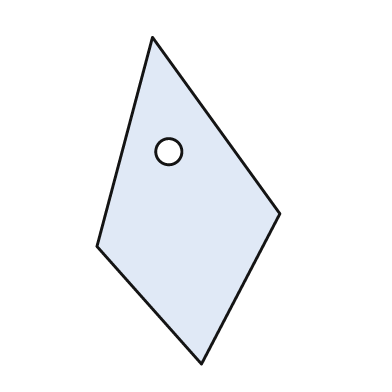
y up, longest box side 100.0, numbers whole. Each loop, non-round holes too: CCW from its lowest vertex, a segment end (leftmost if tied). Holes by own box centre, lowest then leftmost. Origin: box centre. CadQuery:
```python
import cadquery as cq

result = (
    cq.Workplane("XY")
    .moveTo(4.0, -50.0)
    .lineTo(28.0, -4.0)
    .lineTo(-11.0, 50.0)
    .lineTo(-28.0, -14.0)
    .close()
    .moveTo(-6.0, 15.0)
    .circle(4.0)
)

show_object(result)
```